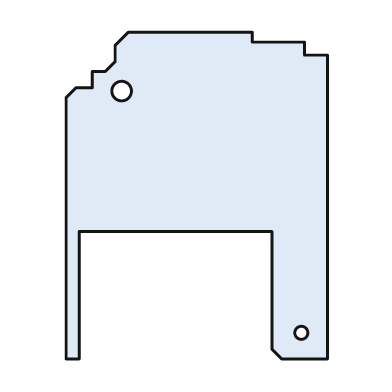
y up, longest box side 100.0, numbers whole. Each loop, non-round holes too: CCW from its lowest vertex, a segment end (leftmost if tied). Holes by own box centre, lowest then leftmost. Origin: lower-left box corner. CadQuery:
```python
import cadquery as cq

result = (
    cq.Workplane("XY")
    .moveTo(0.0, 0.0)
    .lineTo(4.0, 0.0)
    .lineTo(4.0, 39.0)
    .lineTo(63.0, 39.0)
    .lineTo(63.0, 3.0)
    .lineTo(66.0, 0.0)
    .lineTo(80.0, 0.0)
    .lineTo(80.0, 93.0)
    .lineTo(73.0, 93.0)
    .lineTo(73.0, 97.0)
    .lineTo(57.0, 97.0)
    .lineTo(57.0, 100.0)
    .lineTo(19.0, 100.0)
    .lineTo(15.0, 96.0)
    .lineTo(15.0, 91.0)
    .lineTo(12.0, 88.0)
    .lineTo(8.0, 88.0)
    .lineTo(8.0, 83.0)
    .lineTo(3.0, 83.0)
    .lineTo(0.0, 80.0)
    .close()
    .moveTo(72.0, 8.0)
    .circle(2.0)
    .moveTo(17.0, 82.0)
    .circle(3.0)
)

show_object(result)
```